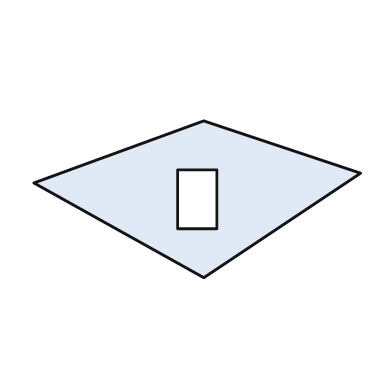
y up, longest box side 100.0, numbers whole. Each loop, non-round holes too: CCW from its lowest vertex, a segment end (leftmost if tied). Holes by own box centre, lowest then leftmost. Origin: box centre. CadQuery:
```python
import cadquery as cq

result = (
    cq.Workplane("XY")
    .moveTo(2.0, -24.0)
    .lineTo(50.0, 8.0)
    .lineTo(2.0, 24.0)
    .lineTo(-50.0, 5.0)
    .close()
    .moveTo(-6.0, -9.0)
    .lineTo(6.0, -9.0)
    .lineTo(6.0, 9.0)
    .lineTo(-6.0, 9.0)
    .close()
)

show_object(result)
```